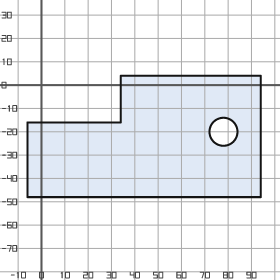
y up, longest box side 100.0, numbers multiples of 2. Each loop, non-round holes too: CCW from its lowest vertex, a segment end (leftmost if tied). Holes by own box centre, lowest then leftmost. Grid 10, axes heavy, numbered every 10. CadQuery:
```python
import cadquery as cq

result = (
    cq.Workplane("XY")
    .moveTo(-6.0, -48.0)
    .lineTo(94.0, -48.0)
    .lineTo(94.0, 4.0)
    .lineTo(34.0, 4.0)
    .lineTo(34.0, -16.0)
    .lineTo(-6.0, -16.0)
    .close()
    .moveTo(78.0, -20.0)
    .circle(6.0)
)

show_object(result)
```